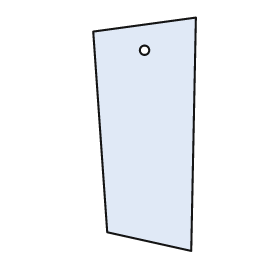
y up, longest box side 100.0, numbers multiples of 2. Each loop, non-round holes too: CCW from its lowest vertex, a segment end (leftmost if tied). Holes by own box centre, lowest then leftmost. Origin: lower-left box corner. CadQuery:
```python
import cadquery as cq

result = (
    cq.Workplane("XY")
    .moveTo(42.0, 0.0)
    .lineTo(44.0, 100.0)
    .lineTo(0.0, 94.0)
    .lineTo(6.0, 8.0)
    .close()
    .moveTo(22.0, 86.0)
    .circle(2.0)
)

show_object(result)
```